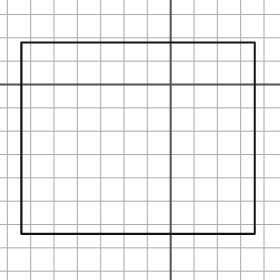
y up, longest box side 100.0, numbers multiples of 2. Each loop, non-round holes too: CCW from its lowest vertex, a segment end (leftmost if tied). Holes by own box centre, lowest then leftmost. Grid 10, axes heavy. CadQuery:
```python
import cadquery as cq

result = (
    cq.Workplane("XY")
    .moveTo(-64.0, -64.0)
    .lineTo(36.0, -64.0)
    .lineTo(36.0, 18.0)
    .lineTo(-64.0, 18.0)
    .close()
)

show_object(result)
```